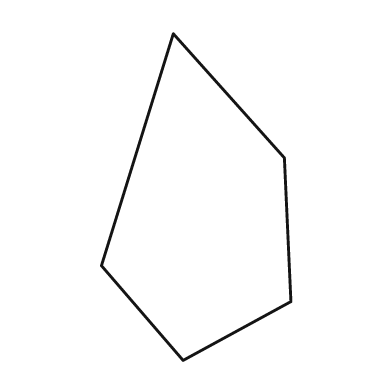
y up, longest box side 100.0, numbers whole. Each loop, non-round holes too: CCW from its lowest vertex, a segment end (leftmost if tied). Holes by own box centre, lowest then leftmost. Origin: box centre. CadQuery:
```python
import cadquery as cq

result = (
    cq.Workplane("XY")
    .moveTo(-4.0, -50.0)
    .lineTo(29.0, -32.0)
    .lineTo(27.0, 12.0)
    .lineTo(-7.0, 50.0)
    .lineTo(-29.0, -21.0)
    .close()
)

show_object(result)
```